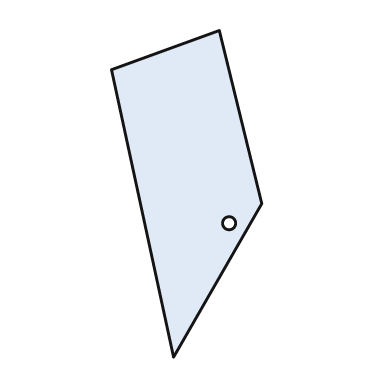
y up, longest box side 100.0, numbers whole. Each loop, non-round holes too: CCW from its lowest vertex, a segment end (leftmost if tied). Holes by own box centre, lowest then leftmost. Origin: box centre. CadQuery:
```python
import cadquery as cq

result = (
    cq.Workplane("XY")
    .moveTo(-4.0, -50.0)
    .lineTo(23.0, -3.0)
    .lineTo(10.0, 50.0)
    .lineTo(-23.0, 38.0)
    .close()
    .moveTo(13.0, -9.0)
    .circle(2.0)
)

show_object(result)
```